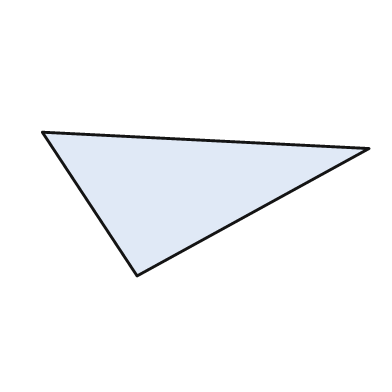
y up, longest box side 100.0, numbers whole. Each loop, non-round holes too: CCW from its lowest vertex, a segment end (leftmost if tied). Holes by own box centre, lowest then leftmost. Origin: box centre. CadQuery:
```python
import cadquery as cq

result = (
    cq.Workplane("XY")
    .moveTo(-21.0, -22.0)
    .lineTo(50.0, 17.0)
    .lineTo(-50.0, 22.0)
    .close()
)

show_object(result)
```